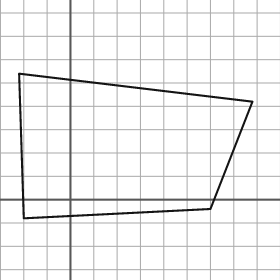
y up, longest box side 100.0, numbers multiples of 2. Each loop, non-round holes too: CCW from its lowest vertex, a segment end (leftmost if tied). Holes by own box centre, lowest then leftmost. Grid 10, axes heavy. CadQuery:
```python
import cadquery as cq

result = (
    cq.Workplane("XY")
    .moveTo(-20.0, -8.0)
    .lineTo(60.0, -4.0)
    .lineTo(78.0, 42.0)
    .lineTo(-22.0, 54.0)
    .close()
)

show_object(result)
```